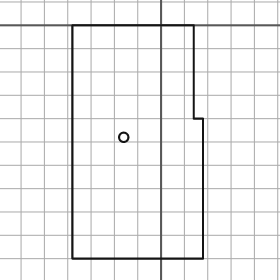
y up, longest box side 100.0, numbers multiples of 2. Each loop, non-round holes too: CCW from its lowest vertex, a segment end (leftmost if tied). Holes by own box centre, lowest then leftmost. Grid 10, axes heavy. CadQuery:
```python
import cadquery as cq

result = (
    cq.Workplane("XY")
    .moveTo(-38.0, -100.0)
    .lineTo(18.0, -100.0)
    .lineTo(18.0, -40.0)
    .lineTo(14.0, -40.0)
    .lineTo(14.0, 0.0)
    .lineTo(-38.0, 0.0)
    .close()
    .moveTo(-16.0, -48.0)
    .circle(2.0)
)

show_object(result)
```